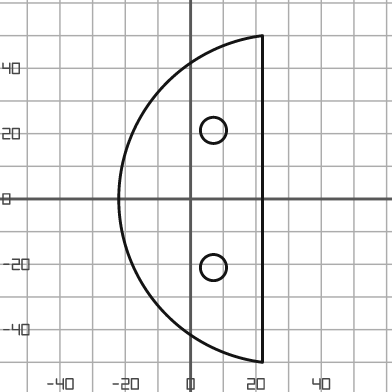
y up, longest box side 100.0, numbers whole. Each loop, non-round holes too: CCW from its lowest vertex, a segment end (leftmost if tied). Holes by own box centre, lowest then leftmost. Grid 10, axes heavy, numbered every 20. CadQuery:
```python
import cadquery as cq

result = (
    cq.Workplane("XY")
    .moveTo(22.0, -50.0)
    .lineTo(22.0, 50.0)
    .threePointArc((-22.0, 0.0), (22.0, -50.0))
    .close()
    .moveTo(7.0, -21.0)
    .circle(4.0)
    .moveTo(7.0, 21.0)
    .circle(4.0)
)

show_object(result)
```